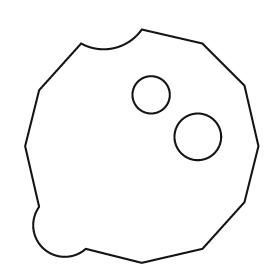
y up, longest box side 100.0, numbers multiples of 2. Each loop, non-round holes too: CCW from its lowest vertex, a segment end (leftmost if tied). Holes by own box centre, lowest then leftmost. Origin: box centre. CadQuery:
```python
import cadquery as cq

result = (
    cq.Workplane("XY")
    .moveTo(0.0, -50.0)
    .lineTo(26.0, -44.0)
    .lineTo(44.0, -24.0)
    .lineTo(50.0, 0.0)
    .lineTo(44.0, 26.0)
    .lineTo(26.0, 44.0)
    .lineTo(0.0, 50.0)
    .threePointArc((-12.0, 42.0), (-26.0, 44.0))
    .lineTo(-44.0, 24.0)
    .lineTo(-50.0, 0.0)
    .lineTo(-44.0, -26.0)
    .threePointArc((-42.0, -44.0), (-24.0, -44.0))
    .close()
    .moveTo(24.0, 4.0)
    .circle(10.0)
    .moveTo(4.0, 22.0)
    .circle(8.0)
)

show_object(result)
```